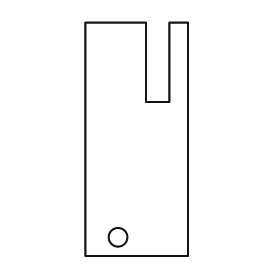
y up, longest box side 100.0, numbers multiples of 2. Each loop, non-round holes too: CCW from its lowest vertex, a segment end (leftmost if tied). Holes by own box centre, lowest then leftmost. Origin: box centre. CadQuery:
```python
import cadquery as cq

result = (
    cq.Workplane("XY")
    .moveTo(-22.0, -50.0)
    .lineTo(22.0, -50.0)
    .lineTo(22.0, 50.0)
    .lineTo(14.0, 50.0)
    .lineTo(14.0, 16.0)
    .lineTo(4.0, 16.0)
    .lineTo(4.0, 50.0)
    .lineTo(-22.0, 50.0)
    .close()
    .moveTo(-8.0, -42.0)
    .circle(4.0)
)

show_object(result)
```